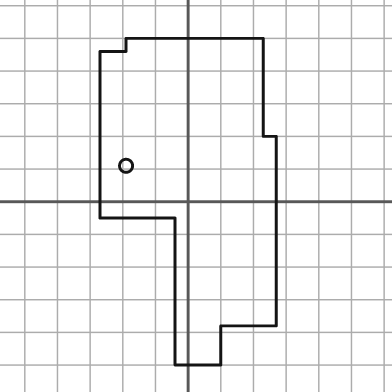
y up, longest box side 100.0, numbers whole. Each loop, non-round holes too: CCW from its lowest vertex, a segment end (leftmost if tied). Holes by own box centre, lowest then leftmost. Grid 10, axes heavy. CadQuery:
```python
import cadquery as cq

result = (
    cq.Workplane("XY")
    .moveTo(-4.0, -50.0)
    .lineTo(10.0, -50.0)
    .lineTo(10.0, -38.0)
    .lineTo(27.0, -38.0)
    .lineTo(27.0, 20.0)
    .lineTo(23.0, 20.0)
    .lineTo(23.0, 50.0)
    .lineTo(-19.0, 50.0)
    .lineTo(-19.0, 46.0)
    .lineTo(-27.0, 46.0)
    .lineTo(-27.0, -5.0)
    .lineTo(-4.0, -5.0)
    .close()
    .moveTo(-19.0, 11.0)
    .circle(2.0)
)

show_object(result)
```